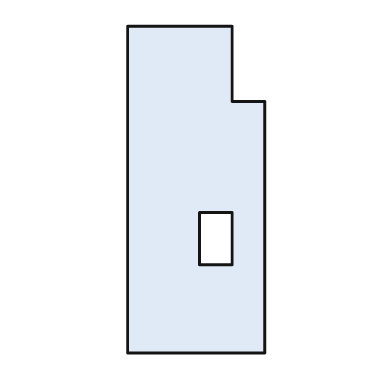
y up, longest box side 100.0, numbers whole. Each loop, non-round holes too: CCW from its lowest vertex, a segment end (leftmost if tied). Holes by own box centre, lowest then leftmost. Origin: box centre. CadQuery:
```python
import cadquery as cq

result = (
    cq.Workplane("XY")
    .moveTo(-21.0, -50.0)
    .lineTo(21.0, -50.0)
    .lineTo(21.0, 27.0)
    .lineTo(11.0, 27.0)
    .lineTo(11.0, 50.0)
    .lineTo(-21.0, 50.0)
    .close()
    .moveTo(1.0, -23.0)
    .lineTo(11.0, -23.0)
    .lineTo(11.0, -7.0)
    .lineTo(1.0, -7.0)
    .close()
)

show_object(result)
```